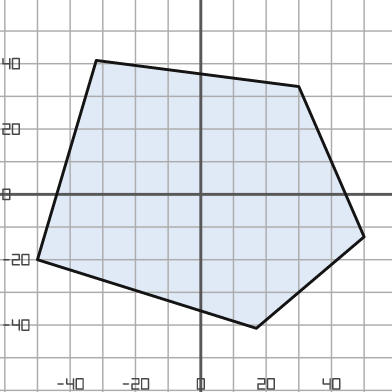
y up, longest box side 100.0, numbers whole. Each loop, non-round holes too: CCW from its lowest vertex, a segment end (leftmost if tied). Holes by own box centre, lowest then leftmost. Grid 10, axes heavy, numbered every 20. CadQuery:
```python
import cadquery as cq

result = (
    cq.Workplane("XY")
    .moveTo(17.0, -41.0)
    .lineTo(50.0, -13.0)
    .lineTo(30.0, 33.0)
    .lineTo(-32.0, 41.0)
    .lineTo(-50.0, -20.0)
    .close()
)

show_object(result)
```